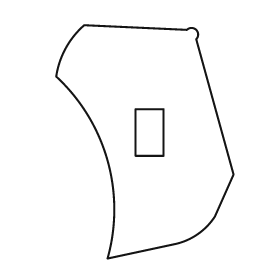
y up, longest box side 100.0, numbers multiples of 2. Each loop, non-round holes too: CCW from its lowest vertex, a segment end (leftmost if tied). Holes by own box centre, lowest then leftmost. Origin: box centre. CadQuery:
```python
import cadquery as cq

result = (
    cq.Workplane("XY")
    .moveTo(-16.0, -50.0)
    .lineTo(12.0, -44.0)
    .threePointArc((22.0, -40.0), (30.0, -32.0))
    .lineTo(38.0, -14.0)
    .lineTo(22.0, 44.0)
    .threePointArc((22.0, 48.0), (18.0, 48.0))
    .lineTo(-26.0, 50.0)
    .threePointArc((-34.0, 40.0), (-38.0, 28.0))
    .threePointArc((-16.0, -8.0), (-16.0, -50.0))
    .close()
    .moveTo(-4.0, -6.0)
    .lineTo(8.0, -6.0)
    .lineTo(8.0, 14.0)
    .lineTo(-4.0, 14.0)
    .close()
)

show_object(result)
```